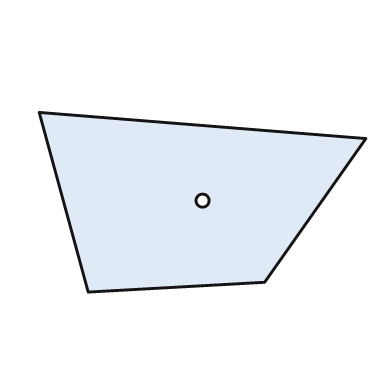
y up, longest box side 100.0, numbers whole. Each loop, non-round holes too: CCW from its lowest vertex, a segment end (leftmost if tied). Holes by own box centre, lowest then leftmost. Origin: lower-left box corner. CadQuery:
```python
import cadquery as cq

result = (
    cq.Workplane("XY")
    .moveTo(15.0, 0.0)
    .lineTo(69.0, 3.0)
    .lineTo(100.0, 47.0)
    .lineTo(0.0, 55.0)
    .close()
    .moveTo(50.0, 28.0)
    .circle(2.0)
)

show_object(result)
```